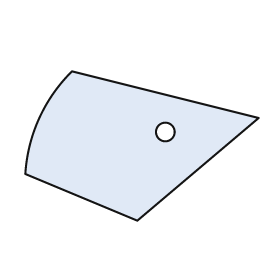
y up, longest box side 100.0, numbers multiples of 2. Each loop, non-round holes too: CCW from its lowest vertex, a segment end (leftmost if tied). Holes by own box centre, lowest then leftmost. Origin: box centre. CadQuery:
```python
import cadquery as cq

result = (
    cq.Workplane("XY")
    .moveTo(-2.0, -32.0)
    .lineTo(50.0, 12.0)
    .lineTo(-30.0, 32.0)
    .threePointArc((-44.0, 12.0), (-50.0, -12.0))
    .close()
    .moveTo(10.0, 6.0)
    .circle(4.0)
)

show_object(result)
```